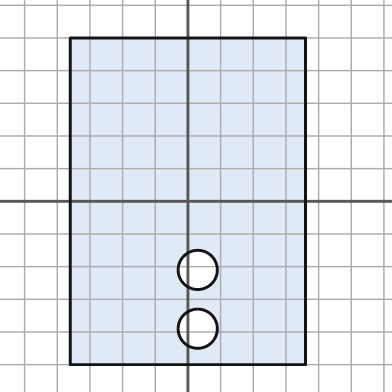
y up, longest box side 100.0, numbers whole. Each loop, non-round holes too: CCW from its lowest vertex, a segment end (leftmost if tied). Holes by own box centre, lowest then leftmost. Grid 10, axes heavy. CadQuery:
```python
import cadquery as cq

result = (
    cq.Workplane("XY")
    .moveTo(-36.0, -50.0)
    .lineTo(36.0, -50.0)
    .lineTo(36.0, 50.0)
    .lineTo(-36.0, 50.0)
    .close()
    .moveTo(3.0, -39.0)
    .circle(6.0)
    .moveTo(3.0, -21.0)
    .circle(6.0)
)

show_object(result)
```